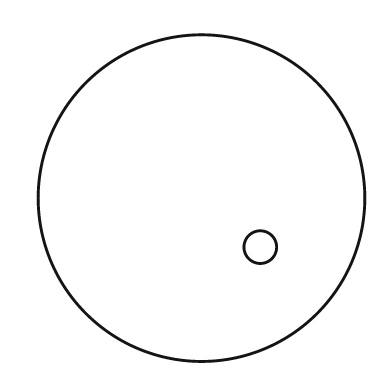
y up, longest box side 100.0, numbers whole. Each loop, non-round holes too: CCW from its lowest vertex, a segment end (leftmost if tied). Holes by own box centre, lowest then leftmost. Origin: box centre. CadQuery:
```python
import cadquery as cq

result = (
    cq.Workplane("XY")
    .moveTo(0.0, 0.0)
    .circle(50.0)
    .moveTo(18.0, -15.0)
    .circle(5.0)
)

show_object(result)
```